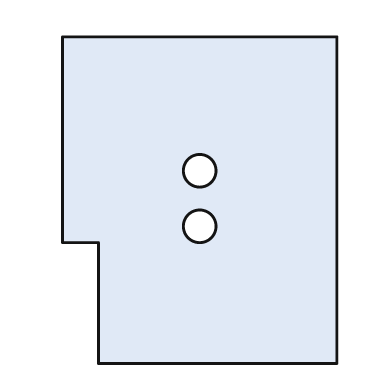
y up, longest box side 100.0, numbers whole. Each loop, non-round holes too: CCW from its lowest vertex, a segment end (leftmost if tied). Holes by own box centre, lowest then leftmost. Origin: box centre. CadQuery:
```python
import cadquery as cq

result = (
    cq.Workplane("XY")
    .moveTo(-31.0, -50.0)
    .lineTo(42.0, -50.0)
    .lineTo(42.0, 50.0)
    .lineTo(-42.0, 50.0)
    .lineTo(-42.0, -13.0)
    .lineTo(-31.0, -13.0)
    .close()
    .moveTo(0.0, -8.0)
    .circle(5.0)
    .moveTo(0.0, 9.0)
    .circle(5.0)
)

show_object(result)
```